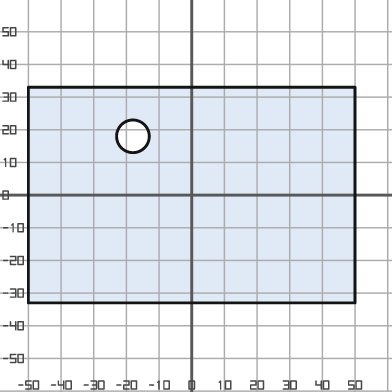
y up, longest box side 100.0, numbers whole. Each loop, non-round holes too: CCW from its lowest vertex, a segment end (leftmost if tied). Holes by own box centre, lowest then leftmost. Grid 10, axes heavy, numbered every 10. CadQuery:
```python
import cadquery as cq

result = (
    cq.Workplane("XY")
    .moveTo(-50.0, -33.0)
    .lineTo(50.0, -33.0)
    .lineTo(50.0, 33.0)
    .lineTo(-50.0, 33.0)
    .close()
    .moveTo(-18.0, 18.0)
    .circle(5.0)
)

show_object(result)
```